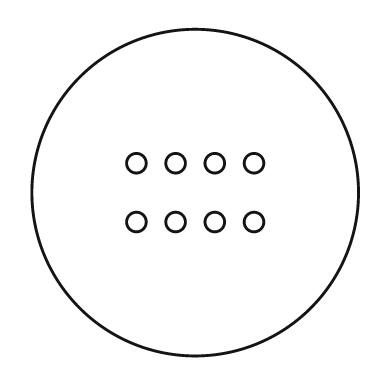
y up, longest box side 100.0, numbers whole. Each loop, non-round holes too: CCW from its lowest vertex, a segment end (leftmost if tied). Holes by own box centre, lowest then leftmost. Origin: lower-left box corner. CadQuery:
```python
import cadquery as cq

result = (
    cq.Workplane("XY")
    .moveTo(50.0, 50.0)
    .circle(50.0)
    .moveTo(32.0, 41.0)
    .circle(3.0)
    .moveTo(44.0, 41.0)
    .circle(3.0)
    .moveTo(56.0, 41.0)
    .circle(3.0)
    .moveTo(68.0, 41.0)
    .circle(3.0)
    .moveTo(32.0, 59.0)
    .circle(3.0)
    .moveTo(44.0, 59.0)
    .circle(3.0)
    .moveTo(56.0, 59.0)
    .circle(3.0)
    .moveTo(68.0, 59.0)
    .circle(3.0)
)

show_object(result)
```